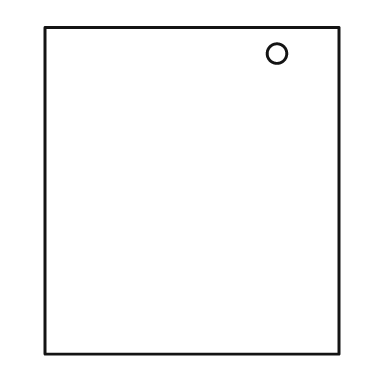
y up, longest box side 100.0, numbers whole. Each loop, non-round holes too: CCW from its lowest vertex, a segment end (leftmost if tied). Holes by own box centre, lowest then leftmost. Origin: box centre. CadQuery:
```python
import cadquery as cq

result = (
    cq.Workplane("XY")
    .moveTo(-45.0, -50.0)
    .lineTo(45.0, -50.0)
    .lineTo(45.0, 50.0)
    .lineTo(-45.0, 50.0)
    .close()
    .moveTo(26.0, 42.0)
    .circle(3.0)
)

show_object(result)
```